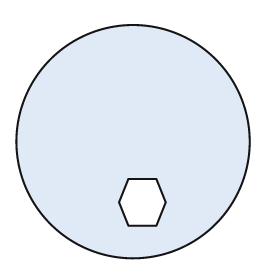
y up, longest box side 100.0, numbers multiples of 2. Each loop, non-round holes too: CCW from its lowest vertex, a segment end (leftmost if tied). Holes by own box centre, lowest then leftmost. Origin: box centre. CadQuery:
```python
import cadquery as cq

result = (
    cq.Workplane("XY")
    .moveTo(0.0, 0.0)
    .circle(50.0)
    .moveTo(-2.0, -36.0)
    .lineTo(10.0, -36.0)
    .lineTo(14.0, -26.0)
    .lineTo(10.0, -16.0)
    .lineTo(-2.0, -16.0)
    .lineTo(-6.0, -26.0)
    .close()
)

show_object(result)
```